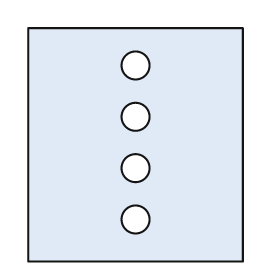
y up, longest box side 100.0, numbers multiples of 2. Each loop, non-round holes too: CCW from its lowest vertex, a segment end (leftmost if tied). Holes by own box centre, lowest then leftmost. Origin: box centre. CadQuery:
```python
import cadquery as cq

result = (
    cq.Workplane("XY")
    .moveTo(-46.0, -50.0)
    .lineTo(46.0, -50.0)
    .lineTo(46.0, 50.0)
    .lineTo(-46.0, 50.0)
    .close()
    .moveTo(0.0, -32.0)
    .circle(6.0)
    .moveTo(0.0, -10.0)
    .circle(6.0)
    .moveTo(0.0, 12.0)
    .circle(6.0)
    .moveTo(0.0, 34.0)
    .circle(6.0)
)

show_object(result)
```